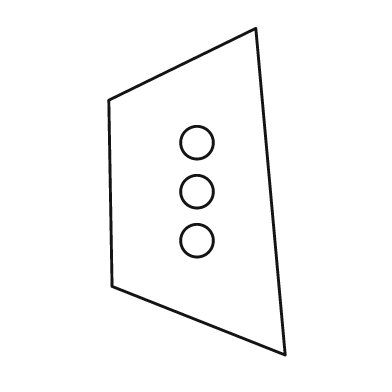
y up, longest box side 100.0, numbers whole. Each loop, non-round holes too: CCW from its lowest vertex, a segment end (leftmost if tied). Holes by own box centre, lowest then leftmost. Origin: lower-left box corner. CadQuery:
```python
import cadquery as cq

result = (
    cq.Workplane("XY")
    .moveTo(54.0, 0.0)
    .lineTo(45.0, 100.0)
    .lineTo(0.0, 78.0)
    .lineTo(1.0, 21.0)
    .close()
    .moveTo(27.0, 35.0)
    .circle(5.0)
    .moveTo(27.0, 50.0)
    .circle(5.0)
    .moveTo(27.0, 65.0)
    .circle(5.0)
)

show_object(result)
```